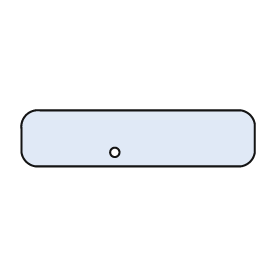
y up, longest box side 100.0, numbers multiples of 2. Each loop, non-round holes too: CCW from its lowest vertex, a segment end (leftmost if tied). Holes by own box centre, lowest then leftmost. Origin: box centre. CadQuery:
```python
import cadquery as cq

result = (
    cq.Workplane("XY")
    .moveTo(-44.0, -12.0)
    .lineTo(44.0, -12.0)
    .threePointArc((48.0, -10.0), (50.0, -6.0))
    .lineTo(50.0, 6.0)
    .threePointArc((48.0, 10.0), (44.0, 12.0))
    .lineTo(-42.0, 12.0)
    .threePointArc((-48.0, 10.0), (-50.0, 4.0))
    .lineTo(-50.0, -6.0)
    .threePointArc((-48.0, -10.0), (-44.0, -12.0))
    .close()
    .moveTo(-10.0, -6.0)
    .circle(2.0)
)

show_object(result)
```